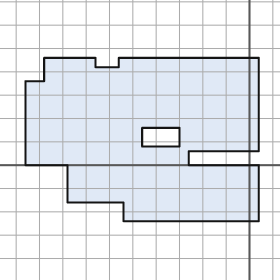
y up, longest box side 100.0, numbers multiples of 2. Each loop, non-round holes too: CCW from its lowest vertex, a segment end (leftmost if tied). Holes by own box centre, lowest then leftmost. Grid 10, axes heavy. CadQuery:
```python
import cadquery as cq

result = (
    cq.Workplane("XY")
    .moveTo(-54.0, -24.0)
    .lineTo(4.0, -24.0)
    .lineTo(4.0, 0.0)
    .lineTo(-26.0, 0.0)
    .lineTo(-26.0, 6.0)
    .lineTo(4.0, 6.0)
    .lineTo(4.0, 46.0)
    .lineTo(-56.0, 46.0)
    .lineTo(-56.0, 42.0)
    .lineTo(-66.0, 42.0)
    .lineTo(-66.0, 46.0)
    .lineTo(-88.0, 46.0)
    .lineTo(-88.0, 36.0)
    .lineTo(-96.0, 36.0)
    .lineTo(-96.0, 0.0)
    .lineTo(-78.0, 0.0)
    .lineTo(-78.0, -16.0)
    .lineTo(-54.0, -16.0)
    .close()
    .moveTo(-46.0, 8.0)
    .lineTo(-30.0, 8.0)
    .lineTo(-30.0, 16.0)
    .lineTo(-46.0, 16.0)
    .close()
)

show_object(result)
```